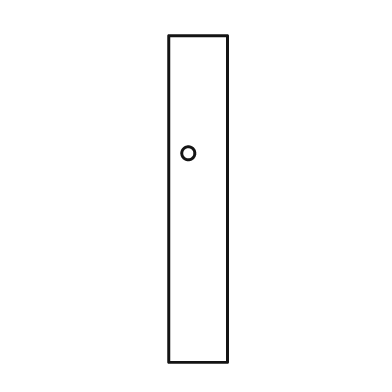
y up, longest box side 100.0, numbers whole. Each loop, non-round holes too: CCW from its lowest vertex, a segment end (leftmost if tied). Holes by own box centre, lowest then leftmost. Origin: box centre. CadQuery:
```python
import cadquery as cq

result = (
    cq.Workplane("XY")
    .moveTo(-9.0, -50.0)
    .lineTo(9.0, -50.0)
    .lineTo(9.0, 50.0)
    .lineTo(-9.0, 50.0)
    .close()
    .moveTo(-3.0, 14.0)
    .circle(2.0)
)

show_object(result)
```